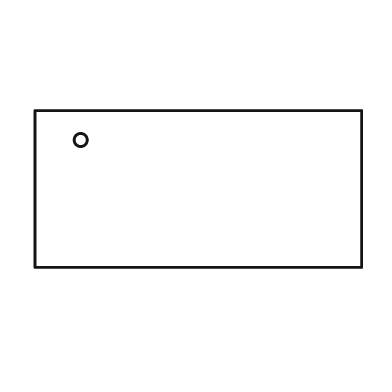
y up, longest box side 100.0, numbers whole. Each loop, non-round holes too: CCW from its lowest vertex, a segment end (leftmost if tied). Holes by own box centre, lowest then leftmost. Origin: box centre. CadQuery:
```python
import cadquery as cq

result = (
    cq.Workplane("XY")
    .moveTo(-50.0, -24.0)
    .lineTo(50.0, -24.0)
    .lineTo(50.0, 24.0)
    .lineTo(-50.0, 24.0)
    .close()
    .moveTo(-36.0, 15.0)
    .circle(2.0)
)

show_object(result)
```